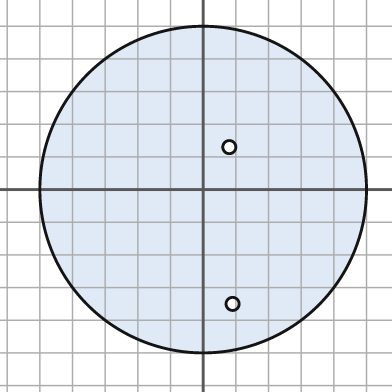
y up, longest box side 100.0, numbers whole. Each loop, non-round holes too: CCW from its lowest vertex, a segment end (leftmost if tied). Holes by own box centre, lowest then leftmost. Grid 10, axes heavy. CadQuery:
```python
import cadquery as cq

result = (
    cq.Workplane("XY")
    .moveTo(0.0, 0.0)
    .circle(50.0)
    .moveTo(9.0, -35.0)
    .circle(2.0)
    .moveTo(8.0, 13.0)
    .circle(2.0)
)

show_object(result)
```